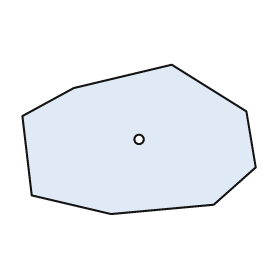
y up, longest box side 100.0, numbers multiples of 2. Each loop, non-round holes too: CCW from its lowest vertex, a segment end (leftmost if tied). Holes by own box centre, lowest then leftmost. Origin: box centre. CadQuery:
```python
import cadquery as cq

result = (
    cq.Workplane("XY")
    .moveTo(-12.0, -32.0)
    .lineTo(32.0, -28.0)
    .lineTo(50.0, -12.0)
    .lineTo(46.0, 12.0)
    .lineTo(14.0, 32.0)
    .lineTo(-28.0, 22.0)
    .lineTo(-50.0, 10.0)
    .lineTo(-46.0, -24.0)
    .close()
    .moveTo(0.0, 0.0)
    .circle(2.0)
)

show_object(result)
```